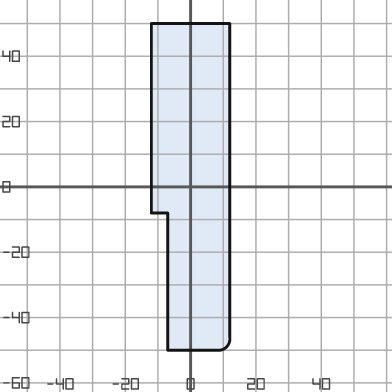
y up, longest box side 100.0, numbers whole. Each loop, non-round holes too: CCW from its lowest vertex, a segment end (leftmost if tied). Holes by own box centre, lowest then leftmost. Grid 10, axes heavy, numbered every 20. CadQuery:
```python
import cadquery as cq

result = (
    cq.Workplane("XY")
    .moveTo(-7.0, -50.0)
    .lineTo(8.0, -50.0)
    .threePointArc((11.0, -49.0), (12.0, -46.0))
    .lineTo(12.0, 50.0)
    .lineTo(-12.0, 50.0)
    .lineTo(-12.0, -8.0)
    .lineTo(-7.0, -8.0)
    .close()
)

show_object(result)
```